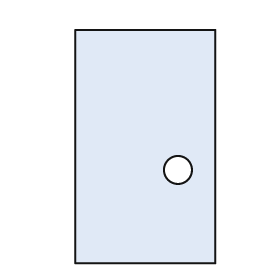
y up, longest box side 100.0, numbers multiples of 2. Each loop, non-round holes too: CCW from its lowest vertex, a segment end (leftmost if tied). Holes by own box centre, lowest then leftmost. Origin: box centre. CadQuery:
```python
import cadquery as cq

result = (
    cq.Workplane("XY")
    .moveTo(-30.0, -50.0)
    .lineTo(30.0, -50.0)
    .lineTo(30.0, 50.0)
    .lineTo(-30.0, 50.0)
    .close()
    .moveTo(14.0, -10.0)
    .circle(6.0)
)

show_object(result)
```